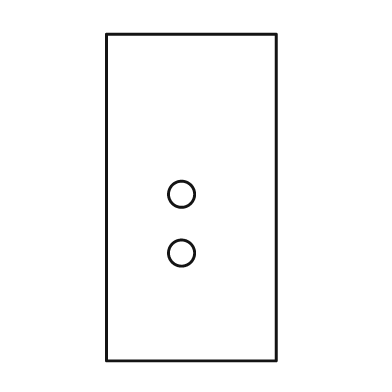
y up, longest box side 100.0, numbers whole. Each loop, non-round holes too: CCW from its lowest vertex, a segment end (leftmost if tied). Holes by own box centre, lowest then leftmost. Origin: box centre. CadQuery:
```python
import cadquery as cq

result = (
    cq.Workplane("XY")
    .moveTo(-26.0, -50.0)
    .lineTo(26.0, -50.0)
    .lineTo(26.0, 50.0)
    .lineTo(-26.0, 50.0)
    .close()
    .moveTo(-3.0, -17.0)
    .circle(4.0)
    .moveTo(-3.0, 1.0)
    .circle(4.0)
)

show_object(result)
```